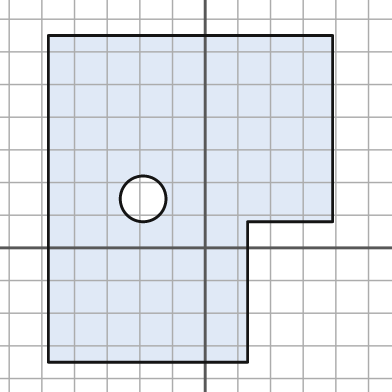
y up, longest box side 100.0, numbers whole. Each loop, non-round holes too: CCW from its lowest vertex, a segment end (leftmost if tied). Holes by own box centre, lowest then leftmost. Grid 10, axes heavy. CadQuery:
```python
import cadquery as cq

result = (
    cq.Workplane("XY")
    .moveTo(-48.0, -35.0)
    .lineTo(13.0, -35.0)
    .lineTo(13.0, 8.0)
    .lineTo(39.0, 8.0)
    .lineTo(39.0, 65.0)
    .lineTo(-48.0, 65.0)
    .close()
    .moveTo(-19.0, 15.0)
    .circle(7.0)
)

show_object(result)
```